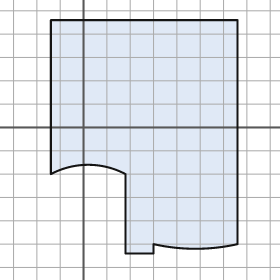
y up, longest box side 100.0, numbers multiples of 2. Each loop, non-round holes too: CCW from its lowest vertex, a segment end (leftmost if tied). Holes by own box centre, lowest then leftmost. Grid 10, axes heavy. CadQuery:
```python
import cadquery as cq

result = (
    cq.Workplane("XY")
    .moveTo(18.0, -54.0)
    .lineTo(30.0, -54.0)
    .lineTo(30.0, -50.0)
    .threePointArc((48.0, -52.0), (66.0, -50.0))
    .lineTo(66.0, 46.0)
    .lineTo(-14.0, 46.0)
    .lineTo(-14.0, -20.0)
    .threePointArc((2.0, -16.0), (18.0, -20.0))
    .close()
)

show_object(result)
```